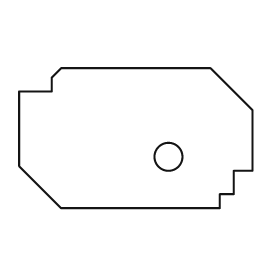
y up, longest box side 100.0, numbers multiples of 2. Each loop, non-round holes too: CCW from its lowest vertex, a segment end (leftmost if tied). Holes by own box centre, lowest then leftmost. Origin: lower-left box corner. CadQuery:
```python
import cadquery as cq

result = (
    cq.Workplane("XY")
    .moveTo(18.0, 0.0)
    .lineTo(86.0, 0.0)
    .lineTo(86.0, 6.0)
    .lineTo(92.0, 6.0)
    .lineTo(92.0, 16.0)
    .lineTo(100.0, 16.0)
    .lineTo(100.0, 42.0)
    .lineTo(82.0, 60.0)
    .lineTo(18.0, 60.0)
    .lineTo(14.0, 56.0)
    .lineTo(14.0, 50.0)
    .lineTo(0.0, 50.0)
    .lineTo(0.0, 18.0)
    .close()
    .moveTo(64.0, 22.0)
    .circle(6.0)
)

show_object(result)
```